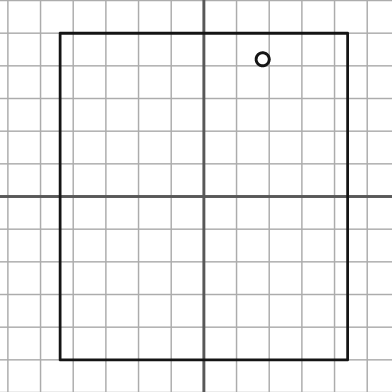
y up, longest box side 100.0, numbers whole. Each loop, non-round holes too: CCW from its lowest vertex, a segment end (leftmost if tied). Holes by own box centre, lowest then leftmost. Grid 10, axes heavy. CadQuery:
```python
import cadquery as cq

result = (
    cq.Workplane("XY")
    .moveTo(-44.0, -50.0)
    .lineTo(44.0, -50.0)
    .lineTo(44.0, 50.0)
    .lineTo(-44.0, 50.0)
    .close()
    .moveTo(18.0, 42.0)
    .circle(2.0)
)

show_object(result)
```